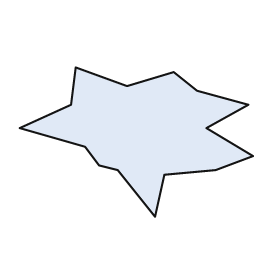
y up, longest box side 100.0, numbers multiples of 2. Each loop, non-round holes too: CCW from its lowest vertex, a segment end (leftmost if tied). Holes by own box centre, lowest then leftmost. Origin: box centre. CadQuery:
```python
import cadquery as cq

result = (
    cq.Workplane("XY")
    .moveTo(8.0, -32.0)
    .lineTo(12.0, -14.0)
    .lineTo(34.0, -12.0)
    .lineTo(50.0, -6.0)
    .lineTo(30.0, 6.0)
    .lineTo(48.0, 16.0)
    .lineTo(26.0, 22.0)
    .lineTo(16.0, 30.0)
    .lineTo(-4.0, 24.0)
    .lineTo(-26.0, 32.0)
    .lineTo(-28.0, 16.0)
    .lineTo(-50.0, 6.0)
    .lineTo(-22.0, -2.0)
    .lineTo(-16.0, -10.0)
    .lineTo(-8.0, -12.0)
    .close()
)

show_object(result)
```